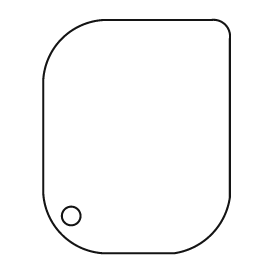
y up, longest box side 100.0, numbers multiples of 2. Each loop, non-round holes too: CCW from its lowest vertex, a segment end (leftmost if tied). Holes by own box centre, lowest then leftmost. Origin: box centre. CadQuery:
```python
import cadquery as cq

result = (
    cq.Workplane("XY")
    .moveTo(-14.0, -50.0)
    .lineTo(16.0, -50.0)
    .threePointArc((32.0, -42.0), (40.0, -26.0))
    .lineTo(40.0, 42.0)
    .threePointArc((38.0, 48.0), (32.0, 50.0))
    .lineTo(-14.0, 50.0)
    .threePointArc((-32.0, 42.0), (-40.0, 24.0))
    .lineTo(-40.0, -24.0)
    .threePointArc((-32.0, -42.0), (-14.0, -50.0))
    .close()
    .moveTo(-28.0, -34.0)
    .circle(4.0)
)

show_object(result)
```